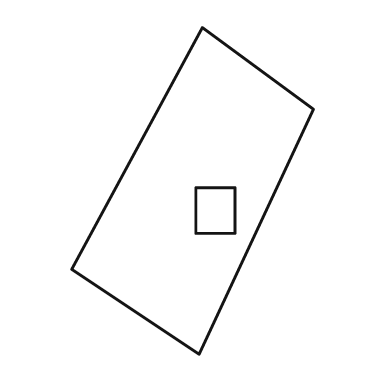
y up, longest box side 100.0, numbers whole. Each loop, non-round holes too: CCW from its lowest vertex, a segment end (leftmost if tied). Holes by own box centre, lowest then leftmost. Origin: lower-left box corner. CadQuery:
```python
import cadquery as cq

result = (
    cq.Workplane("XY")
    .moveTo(39.0, 0.0)
    .lineTo(74.0, 75.0)
    .lineTo(40.0, 100.0)
    .lineTo(0.0, 26.0)
    .close()
    .moveTo(38.0, 37.0)
    .lineTo(50.0, 37.0)
    .lineTo(50.0, 51.0)
    .lineTo(38.0, 51.0)
    .close()
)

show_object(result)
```